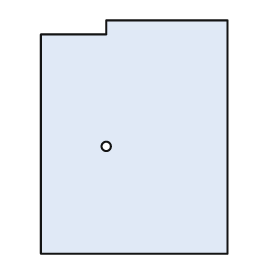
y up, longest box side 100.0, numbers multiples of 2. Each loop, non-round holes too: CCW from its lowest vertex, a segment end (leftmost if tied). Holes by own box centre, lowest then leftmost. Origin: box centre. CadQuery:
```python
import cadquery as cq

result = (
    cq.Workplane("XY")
    .moveTo(-40.0, -50.0)
    .lineTo(40.0, -50.0)
    .lineTo(40.0, 50.0)
    .lineTo(-12.0, 50.0)
    .lineTo(-12.0, 44.0)
    .lineTo(-40.0, 44.0)
    .close()
    .moveTo(-12.0, -4.0)
    .circle(2.0)
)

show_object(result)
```